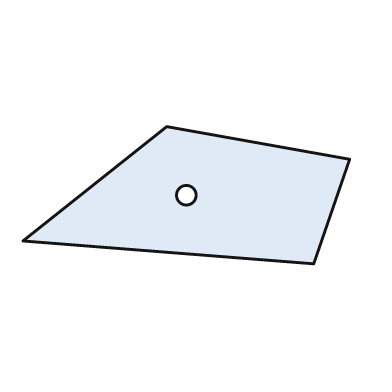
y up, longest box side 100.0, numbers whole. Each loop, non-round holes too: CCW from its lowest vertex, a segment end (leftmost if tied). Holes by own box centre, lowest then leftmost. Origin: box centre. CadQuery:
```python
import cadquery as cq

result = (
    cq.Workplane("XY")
    .moveTo(39.0, -21.0)
    .lineTo(50.0, 11.0)
    .lineTo(-6.0, 21.0)
    .lineTo(-50.0, -14.0)
    .close()
    .moveTo(0.0, 0.0)
    .circle(3.0)
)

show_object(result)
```